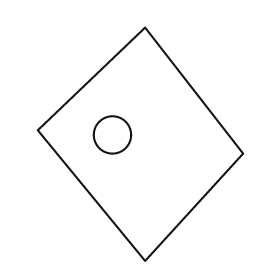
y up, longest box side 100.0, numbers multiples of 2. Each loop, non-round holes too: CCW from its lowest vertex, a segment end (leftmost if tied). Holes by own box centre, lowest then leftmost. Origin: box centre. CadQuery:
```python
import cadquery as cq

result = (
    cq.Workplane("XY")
    .moveTo(2.0, -50.0)
    .lineTo(44.0, -4.0)
    .lineTo(2.0, 50.0)
    .lineTo(-44.0, 6.0)
    .close()
    .moveTo(-12.0, 4.0)
    .circle(8.0)
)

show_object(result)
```